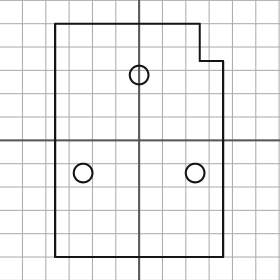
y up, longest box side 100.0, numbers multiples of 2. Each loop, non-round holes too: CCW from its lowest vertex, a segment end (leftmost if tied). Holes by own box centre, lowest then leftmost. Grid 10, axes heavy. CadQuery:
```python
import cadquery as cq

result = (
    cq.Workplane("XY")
    .moveTo(-36.0, -50.0)
    .lineTo(36.0, -50.0)
    .lineTo(36.0, 34.0)
    .lineTo(26.0, 34.0)
    .lineTo(26.0, 50.0)
    .lineTo(-36.0, 50.0)
    .close()
    .moveTo(-24.0, -14.0)
    .circle(4.0)
    .moveTo(24.0, -14.0)
    .circle(4.0)
    .moveTo(0.0, 28.0)
    .circle(4.0)
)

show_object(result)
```